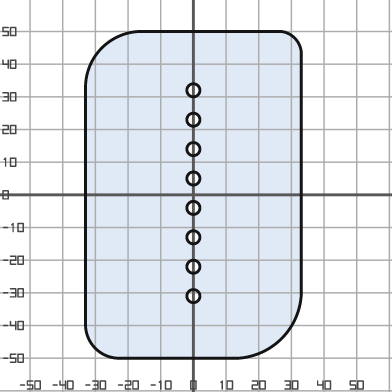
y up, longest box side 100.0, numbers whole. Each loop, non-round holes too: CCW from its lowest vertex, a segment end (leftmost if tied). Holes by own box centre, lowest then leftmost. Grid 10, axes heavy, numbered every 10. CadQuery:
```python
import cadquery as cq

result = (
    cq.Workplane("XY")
    .moveTo(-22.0, -50.0)
    .lineTo(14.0, -50.0)
    .threePointArc((27.0, -44.0), (33.0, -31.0))
    .lineTo(33.0, 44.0)
    .threePointArc((31.0, 48.0), (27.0, 50.0))
    .lineTo(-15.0, 50.0)
    .threePointArc((-28.0, 45.0), (-33.0, 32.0))
    .lineTo(-33.0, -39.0)
    .threePointArc((-30.0, -47.0), (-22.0, -50.0))
    .close()
    .moveTo(0.0, -31.0)
    .circle(2.0)
    .moveTo(0.0, -22.0)
    .circle(2.0)
    .moveTo(0.0, -13.0)
    .circle(2.0)
    .moveTo(0.0, -4.0)
    .circle(2.0)
    .moveTo(0.0, 5.0)
    .circle(2.0)
    .moveTo(0.0, 14.0)
    .circle(2.0)
    .moveTo(0.0, 23.0)
    .circle(2.0)
    .moveTo(0.0, 32.0)
    .circle(2.0)
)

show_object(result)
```